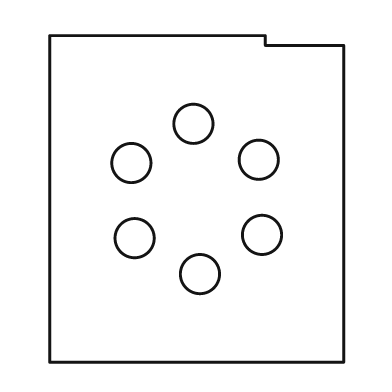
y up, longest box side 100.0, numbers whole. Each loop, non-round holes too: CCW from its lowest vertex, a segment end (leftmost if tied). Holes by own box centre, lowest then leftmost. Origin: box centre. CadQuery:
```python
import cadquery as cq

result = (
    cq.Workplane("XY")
    .moveTo(-45.0, -50.0)
    .lineTo(45.0, -50.0)
    .lineTo(45.0, 47.0)
    .lineTo(21.0, 47.0)
    .lineTo(21.0, 50.0)
    .lineTo(-45.0, 50.0)
    .close()
    .moveTo(1.0, -23.0)
    .circle(6.0)
    .moveTo(-19.0, -12.0)
    .circle(6.0)
    .moveTo(20.0, -11.0)
    .circle(6.0)
    .moveTo(-20.0, 11.0)
    .circle(6.0)
    .moveTo(19.0, 12.0)
    .circle(6.0)
    .moveTo(-1.0, 23.0)
    .circle(6.0)
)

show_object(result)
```